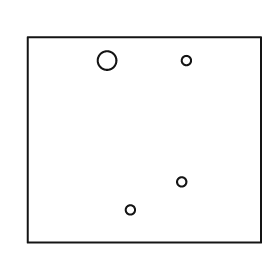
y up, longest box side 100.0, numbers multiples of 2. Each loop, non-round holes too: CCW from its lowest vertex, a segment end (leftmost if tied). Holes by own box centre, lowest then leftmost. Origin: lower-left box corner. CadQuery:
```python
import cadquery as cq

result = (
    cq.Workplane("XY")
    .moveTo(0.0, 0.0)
    .lineTo(100.0, 0.0)
    .lineTo(100.0, 88.0)
    .lineTo(0.0, 88.0)
    .close()
    .moveTo(44.0, 14.0)
    .circle(2.0)
    .moveTo(66.0, 26.0)
    .circle(2.0)
    .moveTo(34.0, 78.0)
    .circle(4.0)
    .moveTo(68.0, 78.0)
    .circle(2.0)
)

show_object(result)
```